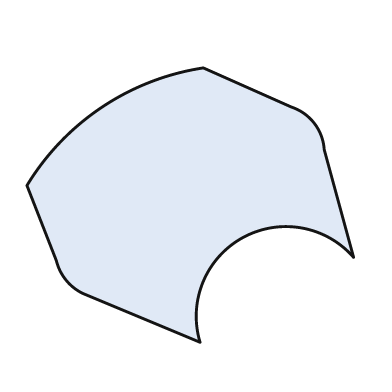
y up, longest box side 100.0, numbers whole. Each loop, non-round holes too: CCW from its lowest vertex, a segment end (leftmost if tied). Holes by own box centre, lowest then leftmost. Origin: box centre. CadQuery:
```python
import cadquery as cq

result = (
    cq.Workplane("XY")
    .moveTo(3.0, -42.0)
    .threePointArc((16.0, -10.0), (50.0, -16.0))
    .lineTo(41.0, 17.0)
    .threePointArc((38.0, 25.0), (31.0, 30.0))
    .lineTo(4.0, 42.0)
    .threePointArc((-27.0, 30.0), (-50.0, 6.0))
    .lineTo(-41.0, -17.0)
    .threePointArc((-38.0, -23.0), (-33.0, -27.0))
    .close()
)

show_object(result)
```